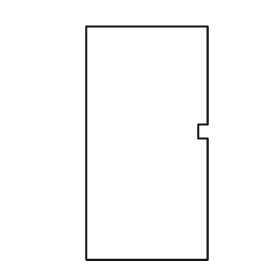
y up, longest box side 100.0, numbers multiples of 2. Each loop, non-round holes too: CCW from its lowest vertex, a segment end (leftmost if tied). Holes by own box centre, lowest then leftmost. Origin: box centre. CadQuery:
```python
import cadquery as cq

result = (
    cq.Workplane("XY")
    .moveTo(-26.0, -50.0)
    .lineTo(26.0, -50.0)
    .lineTo(26.0, 2.0)
    .lineTo(22.0, 2.0)
    .lineTo(22.0, 8.0)
    .lineTo(26.0, 8.0)
    .lineTo(26.0, 50.0)
    .lineTo(-26.0, 50.0)
    .close()
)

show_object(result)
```